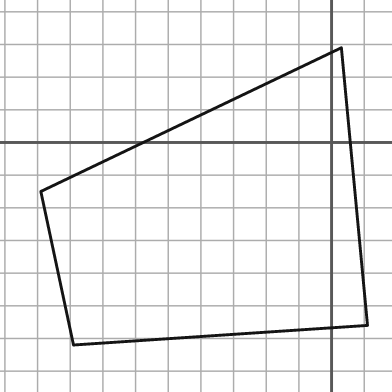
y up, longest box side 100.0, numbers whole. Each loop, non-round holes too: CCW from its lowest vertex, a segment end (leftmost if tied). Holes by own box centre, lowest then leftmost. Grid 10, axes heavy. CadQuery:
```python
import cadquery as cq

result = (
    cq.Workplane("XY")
    .moveTo(-79.0, -62.0)
    .lineTo(11.0, -56.0)
    .lineTo(3.0, 29.0)
    .lineTo(-89.0, -15.0)
    .close()
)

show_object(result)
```